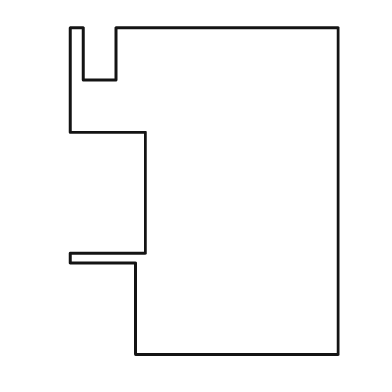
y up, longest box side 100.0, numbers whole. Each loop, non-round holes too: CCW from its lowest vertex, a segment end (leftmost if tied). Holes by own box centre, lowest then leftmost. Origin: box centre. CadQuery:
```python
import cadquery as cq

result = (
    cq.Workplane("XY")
    .moveTo(-21.0, -50.0)
    .lineTo(41.0, -50.0)
    .lineTo(41.0, 50.0)
    .lineTo(-27.0, 50.0)
    .lineTo(-27.0, 34.0)
    .lineTo(-37.0, 34.0)
    .lineTo(-37.0, 50.0)
    .lineTo(-41.0, 50.0)
    .lineTo(-41.0, 18.0)
    .lineTo(-18.0, 18.0)
    .lineTo(-18.0, -19.0)
    .lineTo(-41.0, -19.0)
    .lineTo(-41.0, -22.0)
    .lineTo(-21.0, -22.0)
    .close()
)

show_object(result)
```